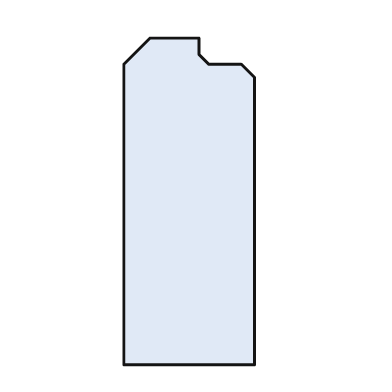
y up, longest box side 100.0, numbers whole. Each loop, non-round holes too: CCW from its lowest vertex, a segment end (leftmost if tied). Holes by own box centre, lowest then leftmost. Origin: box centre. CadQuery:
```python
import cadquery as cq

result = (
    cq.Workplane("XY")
    .moveTo(-20.0, -50.0)
    .lineTo(20.0, -50.0)
    .lineTo(20.0, 38.0)
    .lineTo(16.0, 42.0)
    .lineTo(6.0, 42.0)
    .lineTo(3.0, 45.0)
    .lineTo(3.0, 50.0)
    .lineTo(-12.0, 50.0)
    .lineTo(-20.0, 42.0)
    .close()
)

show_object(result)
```